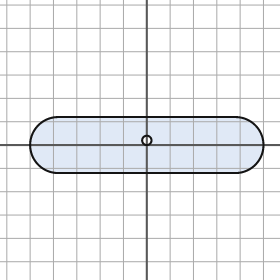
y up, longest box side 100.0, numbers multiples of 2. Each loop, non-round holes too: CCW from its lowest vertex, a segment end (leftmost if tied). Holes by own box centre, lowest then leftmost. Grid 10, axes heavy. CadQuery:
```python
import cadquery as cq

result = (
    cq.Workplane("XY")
    .moveTo(-38.0, -12.0)
    .lineTo(38.0, -12.0)
    .threePointArc((50.0, 0.0), (38.0, 12.0))
    .lineTo(-38.0, 12.0)
    .threePointArc((-50.0, 0.0), (-38.0, -12.0))
    .close()
    .moveTo(0.0, 2.0)
    .circle(2.0)
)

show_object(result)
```